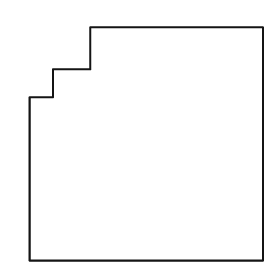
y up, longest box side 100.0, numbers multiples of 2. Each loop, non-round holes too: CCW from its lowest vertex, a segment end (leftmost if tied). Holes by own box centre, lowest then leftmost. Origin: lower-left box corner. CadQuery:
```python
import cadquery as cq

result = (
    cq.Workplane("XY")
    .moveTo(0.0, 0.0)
    .lineTo(100.0, 0.0)
    .lineTo(100.0, 100.0)
    .lineTo(26.0, 100.0)
    .lineTo(26.0, 82.0)
    .lineTo(10.0, 82.0)
    .lineTo(10.0, 70.0)
    .lineTo(0.0, 70.0)
    .close()
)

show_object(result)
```